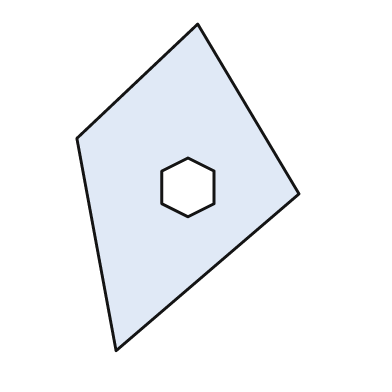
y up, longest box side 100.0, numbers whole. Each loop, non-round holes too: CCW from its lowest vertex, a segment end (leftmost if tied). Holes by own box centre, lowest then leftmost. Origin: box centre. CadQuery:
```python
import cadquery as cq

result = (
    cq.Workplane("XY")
    .moveTo(-22.0, -50.0)
    .lineTo(34.0, -2.0)
    .lineTo(3.0, 50.0)
    .lineTo(-34.0, 15.0)
    .close()
    .moveTo(0.0, -9.0)
    .lineTo(8.0, -5.0)
    .lineTo(8.0, 5.0)
    .lineTo(0.0, 9.0)
    .lineTo(-8.0, 5.0)
    .lineTo(-8.0, -5.0)
    .close()
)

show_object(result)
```